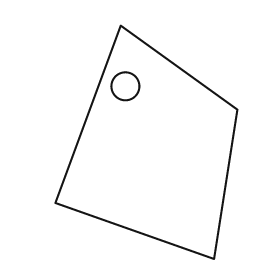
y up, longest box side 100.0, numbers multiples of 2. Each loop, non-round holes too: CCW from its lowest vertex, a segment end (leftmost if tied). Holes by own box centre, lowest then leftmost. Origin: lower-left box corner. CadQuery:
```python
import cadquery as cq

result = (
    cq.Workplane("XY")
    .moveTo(68.0, 0.0)
    .lineTo(78.0, 64.0)
    .lineTo(28.0, 100.0)
    .lineTo(0.0, 24.0)
    .close()
    .moveTo(30.0, 74.0)
    .circle(6.0)
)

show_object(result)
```